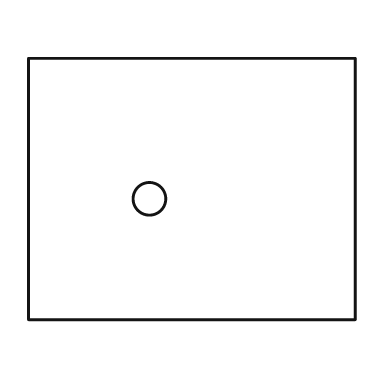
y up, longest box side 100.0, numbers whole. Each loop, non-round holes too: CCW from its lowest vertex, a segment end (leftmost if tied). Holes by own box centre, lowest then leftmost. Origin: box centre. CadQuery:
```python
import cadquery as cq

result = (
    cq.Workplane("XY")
    .moveTo(-50.0, -40.0)
    .lineTo(50.0, -40.0)
    .lineTo(50.0, 40.0)
    .lineTo(-50.0, 40.0)
    .close()
    .moveTo(-13.0, -3.0)
    .circle(5.0)
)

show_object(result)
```